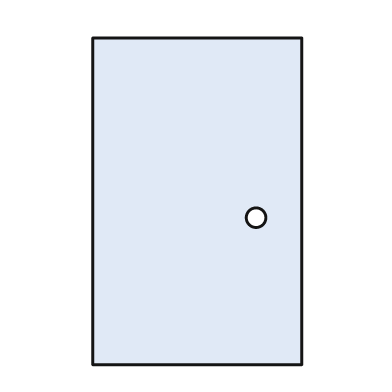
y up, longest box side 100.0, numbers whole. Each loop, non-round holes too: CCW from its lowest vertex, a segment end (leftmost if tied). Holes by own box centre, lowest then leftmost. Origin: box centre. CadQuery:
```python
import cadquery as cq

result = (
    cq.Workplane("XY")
    .moveTo(-32.0, -50.0)
    .lineTo(32.0, -50.0)
    .lineTo(32.0, 50.0)
    .lineTo(-32.0, 50.0)
    .close()
    .moveTo(18.0, -5.0)
    .circle(3.0)
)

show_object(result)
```